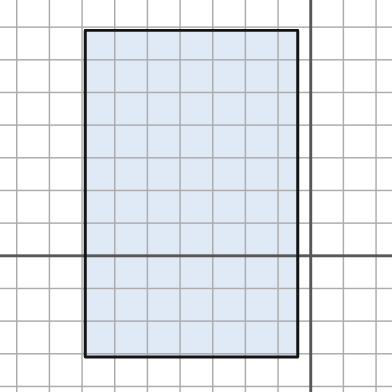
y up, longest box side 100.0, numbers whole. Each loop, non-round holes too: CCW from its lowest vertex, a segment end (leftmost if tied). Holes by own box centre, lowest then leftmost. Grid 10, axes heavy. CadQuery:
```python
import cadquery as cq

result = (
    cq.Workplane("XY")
    .moveTo(-69.0, -31.0)
    .lineTo(-4.0, -31.0)
    .lineTo(-4.0, 69.0)
    .lineTo(-69.0, 69.0)
    .close()
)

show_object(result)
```